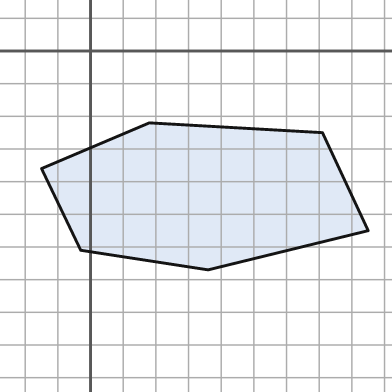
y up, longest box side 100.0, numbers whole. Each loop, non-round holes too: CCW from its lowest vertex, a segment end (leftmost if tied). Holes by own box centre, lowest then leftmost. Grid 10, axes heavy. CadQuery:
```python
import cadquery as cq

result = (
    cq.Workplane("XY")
    .moveTo(36.0, -67.0)
    .lineTo(85.0, -55.0)
    .lineTo(71.0, -25.0)
    .lineTo(18.0, -22.0)
    .lineTo(-15.0, -36.0)
    .lineTo(-3.0, -61.0)
    .close()
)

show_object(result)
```